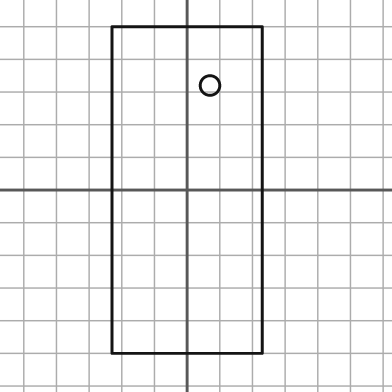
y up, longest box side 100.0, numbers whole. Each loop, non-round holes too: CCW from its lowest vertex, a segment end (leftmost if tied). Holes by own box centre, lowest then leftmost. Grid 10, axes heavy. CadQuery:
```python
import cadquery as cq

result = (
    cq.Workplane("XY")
    .moveTo(-23.0, -50.0)
    .lineTo(23.0, -50.0)
    .lineTo(23.0, 50.0)
    .lineTo(-23.0, 50.0)
    .close()
    .moveTo(7.0, 32.0)
    .circle(3.0)
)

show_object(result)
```